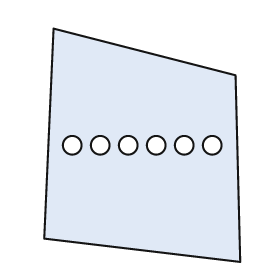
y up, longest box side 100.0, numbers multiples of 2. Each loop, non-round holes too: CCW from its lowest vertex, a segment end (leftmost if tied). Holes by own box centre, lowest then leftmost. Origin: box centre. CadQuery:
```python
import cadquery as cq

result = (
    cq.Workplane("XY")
    .moveTo(42.0, -50.0)
    .lineTo(40.0, 30.0)
    .lineTo(-38.0, 50.0)
    .lineTo(-42.0, -40.0)
    .close()
    .moveTo(-30.0, 0.0)
    .circle(4.0)
    .moveTo(-18.0, 0.0)
    .circle(4.0)
    .moveTo(-6.0, 0.0)
    .circle(4.0)
    .moveTo(6.0, 0.0)
    .circle(4.0)
    .moveTo(18.0, 0.0)
    .circle(4.0)
    .moveTo(30.0, 0.0)
    .circle(4.0)
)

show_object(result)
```